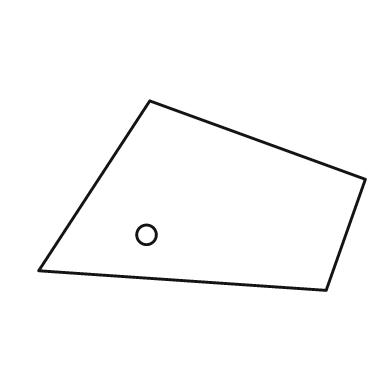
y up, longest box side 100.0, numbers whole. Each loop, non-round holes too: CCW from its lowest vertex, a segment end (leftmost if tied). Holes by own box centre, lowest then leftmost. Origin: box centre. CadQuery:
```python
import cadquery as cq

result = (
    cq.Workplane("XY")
    .moveTo(38.0, -29.0)
    .lineTo(50.0, 5.0)
    .lineTo(-16.0, 29.0)
    .lineTo(-50.0, -23.0)
    .close()
    .moveTo(-17.0, -12.0)
    .circle(3.0)
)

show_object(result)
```